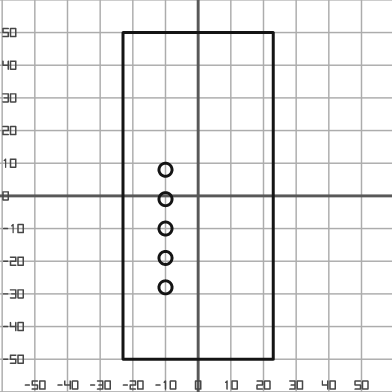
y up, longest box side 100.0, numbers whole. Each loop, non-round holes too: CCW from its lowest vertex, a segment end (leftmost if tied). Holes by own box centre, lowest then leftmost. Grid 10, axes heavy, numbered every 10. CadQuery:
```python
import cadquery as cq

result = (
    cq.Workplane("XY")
    .moveTo(-23.0, -50.0)
    .lineTo(23.0, -50.0)
    .lineTo(23.0, 50.0)
    .lineTo(-23.0, 50.0)
    .close()
    .moveTo(-10.0, -28.0)
    .circle(2.0)
    .moveTo(-10.0, -19.0)
    .circle(2.0)
    .moveTo(-10.0, -10.0)
    .circle(2.0)
    .moveTo(-10.0, -1.0)
    .circle(2.0)
    .moveTo(-10.0, 8.0)
    .circle(2.0)
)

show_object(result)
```